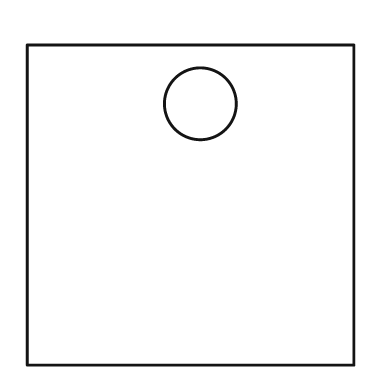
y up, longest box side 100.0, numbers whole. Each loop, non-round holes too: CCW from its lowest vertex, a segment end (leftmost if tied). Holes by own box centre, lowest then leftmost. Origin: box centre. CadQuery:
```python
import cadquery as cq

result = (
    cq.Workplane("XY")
    .moveTo(-50.0, -49.0)
    .lineTo(50.0, -49.0)
    .lineTo(50.0, 49.0)
    .lineTo(-50.0, 49.0)
    .close()
    .moveTo(3.0, 31.0)
    .circle(11.0)
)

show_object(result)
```